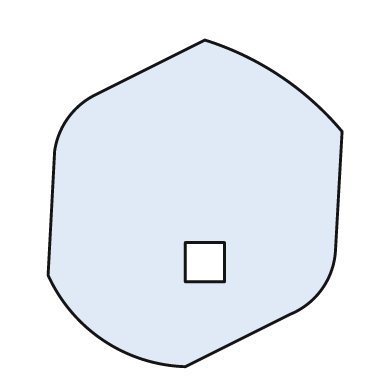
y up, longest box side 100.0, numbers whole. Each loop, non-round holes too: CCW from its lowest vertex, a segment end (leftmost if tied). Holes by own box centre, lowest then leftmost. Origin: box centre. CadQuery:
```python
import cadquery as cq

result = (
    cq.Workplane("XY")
    .moveTo(-3.0, -50.0)
    .lineTo(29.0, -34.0)
    .threePointArc((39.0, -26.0), (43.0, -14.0))
    .lineTo(45.0, 22.0)
    .threePointArc((26.0, 39.0), (3.0, 50.0))
    .lineTo(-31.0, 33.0)
    .threePointArc((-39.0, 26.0), (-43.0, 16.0))
    .lineTo(-45.0, -22.0)
    .threePointArc((-28.0, -42.0), (-3.0, -50.0))
    .close()
    .moveTo(-3.0, -24.0)
    .lineTo(9.0, -24.0)
    .lineTo(9.0, -12.0)
    .lineTo(-3.0, -12.0)
    .close()
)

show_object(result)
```